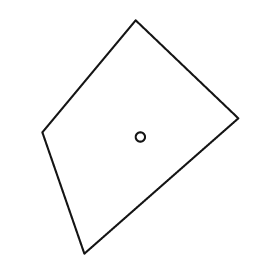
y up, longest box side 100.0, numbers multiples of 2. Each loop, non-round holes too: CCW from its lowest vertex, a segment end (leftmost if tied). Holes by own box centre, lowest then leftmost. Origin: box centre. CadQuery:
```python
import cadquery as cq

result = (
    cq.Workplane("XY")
    .moveTo(-24.0, -50.0)
    .lineTo(42.0, 8.0)
    .lineTo(-2.0, 50.0)
    .lineTo(-42.0, 2.0)
    .close()
    .moveTo(0.0, 0.0)
    .circle(2.0)
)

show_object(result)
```